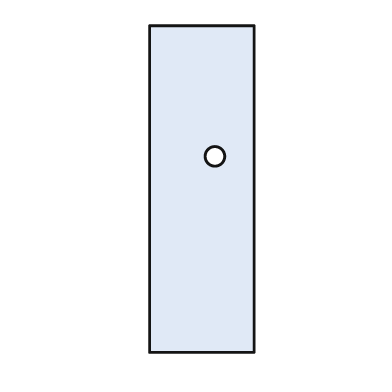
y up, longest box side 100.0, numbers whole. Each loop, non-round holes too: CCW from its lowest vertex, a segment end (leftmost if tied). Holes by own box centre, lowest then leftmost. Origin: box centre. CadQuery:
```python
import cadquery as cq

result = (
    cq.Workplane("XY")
    .moveTo(-16.0, -50.0)
    .lineTo(16.0, -50.0)
    .lineTo(16.0, 50.0)
    .lineTo(-16.0, 50.0)
    .close()
    .moveTo(4.0, 10.0)
    .circle(3.0)
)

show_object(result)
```